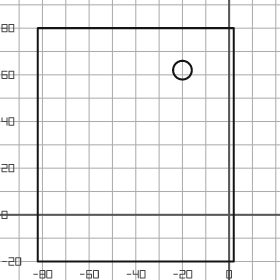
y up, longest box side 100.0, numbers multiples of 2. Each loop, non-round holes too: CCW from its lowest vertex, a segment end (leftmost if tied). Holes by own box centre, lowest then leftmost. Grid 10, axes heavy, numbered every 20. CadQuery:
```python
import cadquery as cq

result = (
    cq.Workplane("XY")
    .moveTo(-82.0, -20.0)
    .lineTo(2.0, -20.0)
    .lineTo(2.0, 80.0)
    .lineTo(-82.0, 80.0)
    .close()
    .moveTo(-20.0, 62.0)
    .circle(4.0)
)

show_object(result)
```